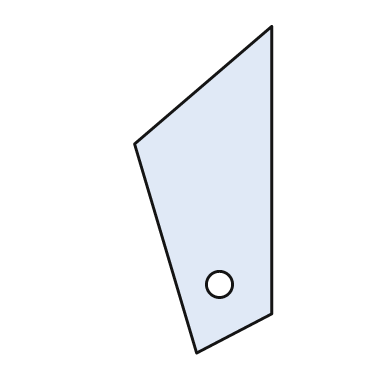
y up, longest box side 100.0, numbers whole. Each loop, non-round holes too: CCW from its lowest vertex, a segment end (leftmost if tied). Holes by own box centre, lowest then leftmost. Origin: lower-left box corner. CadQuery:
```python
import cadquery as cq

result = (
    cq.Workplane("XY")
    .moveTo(19.0, 0.0)
    .lineTo(42.0, 12.0)
    .lineTo(42.0, 100.0)
    .lineTo(0.0, 64.0)
    .close()
    .moveTo(26.0, 21.0)
    .circle(4.0)
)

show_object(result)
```